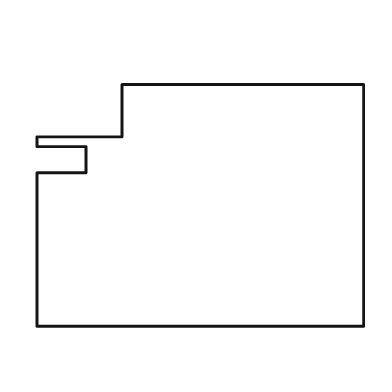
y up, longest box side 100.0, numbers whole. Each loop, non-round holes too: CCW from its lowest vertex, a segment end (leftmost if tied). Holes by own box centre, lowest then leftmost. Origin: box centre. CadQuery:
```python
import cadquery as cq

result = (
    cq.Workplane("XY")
    .moveTo(-50.0, -37.0)
    .lineTo(50.0, -37.0)
    .lineTo(50.0, 37.0)
    .lineTo(-24.0, 37.0)
    .lineTo(-24.0, 21.0)
    .lineTo(-50.0, 21.0)
    .lineTo(-50.0, 18.0)
    .lineTo(-35.0, 18.0)
    .lineTo(-35.0, 10.0)
    .lineTo(-50.0, 10.0)
    .close()
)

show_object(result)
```